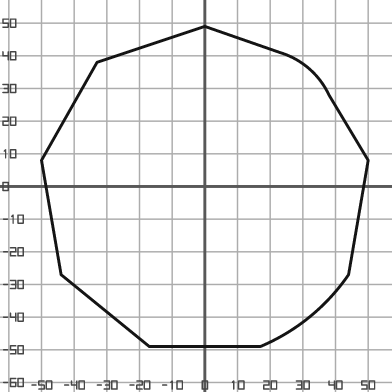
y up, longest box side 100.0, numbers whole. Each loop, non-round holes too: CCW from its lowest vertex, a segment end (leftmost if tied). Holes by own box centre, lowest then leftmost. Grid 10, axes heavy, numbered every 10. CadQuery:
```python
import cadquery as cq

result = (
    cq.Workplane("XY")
    .moveTo(-17.0, -49.0)
    .lineTo(17.0, -49.0)
    .threePointArc((32.0, -40.0), (44.0, -27.0))
    .lineTo(50.0, 8.0)
    .lineTo(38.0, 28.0)
    .threePointArc((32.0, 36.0), (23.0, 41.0))
    .lineTo(0.0, 49.0)
    .lineTo(-33.0, 38.0)
    .lineTo(-50.0, 8.0)
    .lineTo(-44.0, -27.0)
    .close()
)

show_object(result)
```